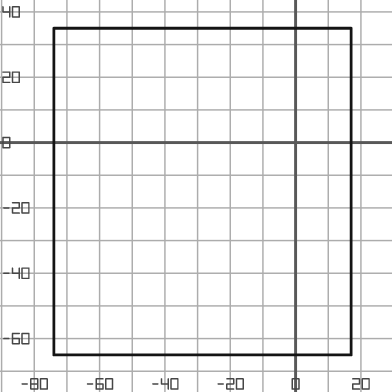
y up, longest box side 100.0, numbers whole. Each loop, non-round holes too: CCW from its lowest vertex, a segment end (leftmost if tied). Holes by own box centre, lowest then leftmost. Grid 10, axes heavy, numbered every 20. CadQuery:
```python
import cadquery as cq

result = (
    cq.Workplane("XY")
    .moveTo(-74.0, -65.0)
    .lineTo(17.0, -65.0)
    .lineTo(17.0, 35.0)
    .lineTo(-74.0, 35.0)
    .close()
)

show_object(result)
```